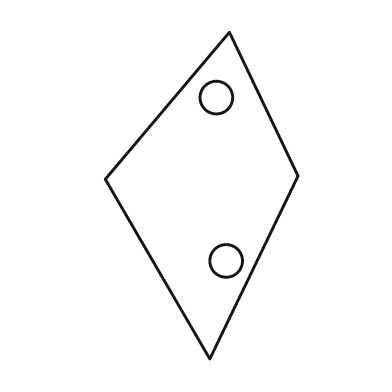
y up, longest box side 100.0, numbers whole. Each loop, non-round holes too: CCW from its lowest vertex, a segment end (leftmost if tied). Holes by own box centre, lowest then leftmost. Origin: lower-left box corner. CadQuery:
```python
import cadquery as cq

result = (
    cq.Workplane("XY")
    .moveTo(32.0, 0.0)
    .lineTo(59.0, 56.0)
    .lineTo(38.0, 100.0)
    .lineTo(0.0, 55.0)
    .close()
    .moveTo(37.0, 30.0)
    .circle(5.0)
    .moveTo(34.0, 80.0)
    .circle(5.0)
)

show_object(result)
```